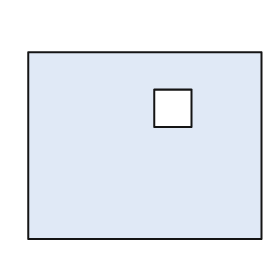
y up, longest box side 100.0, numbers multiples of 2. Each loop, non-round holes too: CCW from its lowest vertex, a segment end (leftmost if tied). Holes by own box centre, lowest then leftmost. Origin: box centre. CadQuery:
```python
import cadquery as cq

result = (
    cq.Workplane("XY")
    .moveTo(-50.0, -40.0)
    .lineTo(50.0, -40.0)
    .lineTo(50.0, 40.0)
    .lineTo(-50.0, 40.0)
    .close()
    .moveTo(4.0, 8.0)
    .lineTo(20.0, 8.0)
    .lineTo(20.0, 24.0)
    .lineTo(4.0, 24.0)
    .close()
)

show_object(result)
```